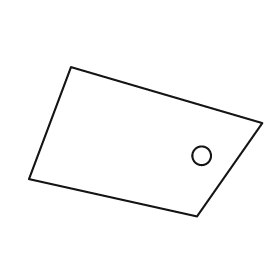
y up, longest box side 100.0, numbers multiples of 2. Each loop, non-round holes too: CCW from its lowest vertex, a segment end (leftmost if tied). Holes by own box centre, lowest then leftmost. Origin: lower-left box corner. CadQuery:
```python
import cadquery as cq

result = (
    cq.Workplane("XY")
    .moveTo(72.0, 0.0)
    .lineTo(100.0, 40.0)
    .lineTo(18.0, 64.0)
    .lineTo(0.0, 16.0)
    .close()
    .moveTo(74.0, 26.0)
    .circle(4.0)
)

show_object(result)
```